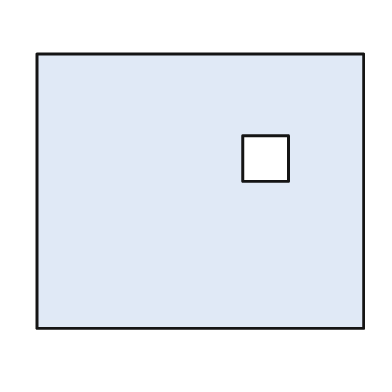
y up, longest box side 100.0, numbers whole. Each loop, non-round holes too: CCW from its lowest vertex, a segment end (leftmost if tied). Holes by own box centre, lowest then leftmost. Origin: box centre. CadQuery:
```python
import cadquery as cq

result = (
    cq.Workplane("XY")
    .moveTo(-50.0, -42.0)
    .lineTo(50.0, -42.0)
    .lineTo(50.0, 42.0)
    .lineTo(-50.0, 42.0)
    .close()
    .moveTo(13.0, 3.0)
    .lineTo(27.0, 3.0)
    .lineTo(27.0, 17.0)
    .lineTo(13.0, 17.0)
    .close()
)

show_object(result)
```